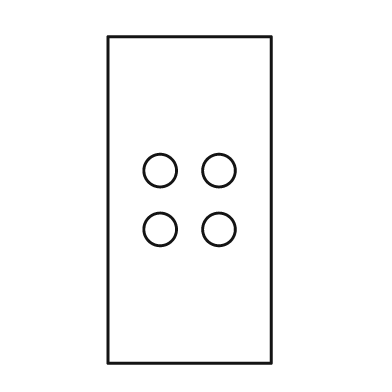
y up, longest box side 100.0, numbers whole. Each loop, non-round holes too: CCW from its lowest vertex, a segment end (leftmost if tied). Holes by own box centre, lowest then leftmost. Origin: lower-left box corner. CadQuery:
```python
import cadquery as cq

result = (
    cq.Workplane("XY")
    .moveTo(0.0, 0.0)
    .lineTo(50.0, 0.0)
    .lineTo(50.0, 100.0)
    .lineTo(0.0, 100.0)
    .close()
    .moveTo(16.0, 41.0)
    .circle(5.0)
    .moveTo(34.0, 41.0)
    .circle(5.0)
    .moveTo(16.0, 59.0)
    .circle(5.0)
    .moveTo(34.0, 59.0)
    .circle(5.0)
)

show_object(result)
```